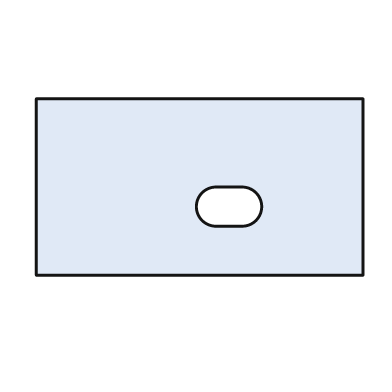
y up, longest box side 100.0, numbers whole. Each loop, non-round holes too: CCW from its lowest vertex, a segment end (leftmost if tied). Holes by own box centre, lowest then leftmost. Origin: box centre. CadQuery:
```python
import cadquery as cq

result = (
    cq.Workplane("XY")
    .moveTo(-50.0, -27.0)
    .lineTo(50.0, -27.0)
    .lineTo(50.0, 27.0)
    .lineTo(-50.0, 27.0)
    .close()
    .moveTo(5.0, -12.0)
    .lineTo(13.0, -12.0)
    .threePointArc((19.0, -6.0), (13.0, 0.0))
    .lineTo(5.0, 0.0)
    .threePointArc((-1.0, -6.0), (5.0, -12.0))
    .close()
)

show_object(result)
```